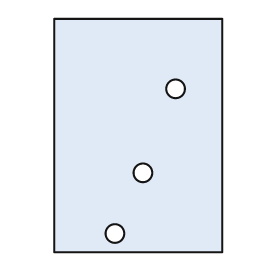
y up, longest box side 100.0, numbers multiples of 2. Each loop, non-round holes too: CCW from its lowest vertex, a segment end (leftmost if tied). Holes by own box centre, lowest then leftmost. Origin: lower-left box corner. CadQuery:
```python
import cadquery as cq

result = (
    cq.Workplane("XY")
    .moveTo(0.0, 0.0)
    .lineTo(72.0, 0.0)
    .lineTo(72.0, 100.0)
    .lineTo(0.0, 100.0)
    .close()
    .moveTo(26.0, 8.0)
    .circle(4.0)
    .moveTo(38.0, 34.0)
    .circle(4.0)
    .moveTo(52.0, 70.0)
    .circle(4.0)
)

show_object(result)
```